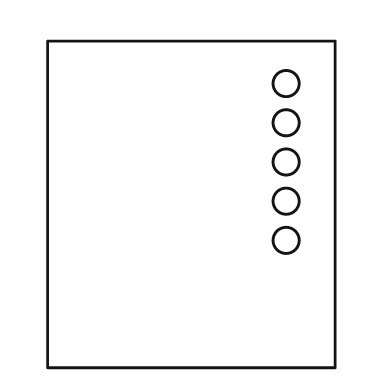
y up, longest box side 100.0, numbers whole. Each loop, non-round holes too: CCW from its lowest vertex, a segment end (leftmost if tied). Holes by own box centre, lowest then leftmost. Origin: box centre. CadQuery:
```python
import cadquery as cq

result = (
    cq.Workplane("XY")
    .moveTo(-44.0, -50.0)
    .lineTo(44.0, -50.0)
    .lineTo(44.0, 50.0)
    .lineTo(-44.0, 50.0)
    .close()
    .moveTo(29.0, -11.0)
    .circle(4.0)
    .moveTo(29.0, 1.0)
    .circle(4.0)
    .moveTo(29.0, 13.0)
    .circle(4.0)
    .moveTo(29.0, 25.0)
    .circle(4.0)
    .moveTo(29.0, 37.0)
    .circle(4.0)
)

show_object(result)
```